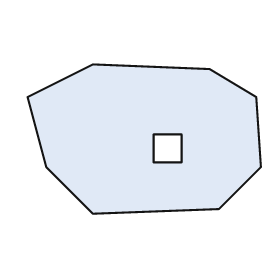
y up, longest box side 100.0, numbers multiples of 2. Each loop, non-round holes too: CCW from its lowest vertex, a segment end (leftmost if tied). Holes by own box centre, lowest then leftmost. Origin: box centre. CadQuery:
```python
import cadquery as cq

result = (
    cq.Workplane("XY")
    .moveTo(-22.0, -32.0)
    .lineTo(32.0, -30.0)
    .lineTo(50.0, -12.0)
    .lineTo(48.0, 18.0)
    .lineTo(28.0, 30.0)
    .lineTo(-22.0, 32.0)
    .lineTo(-50.0, 18.0)
    .lineTo(-42.0, -12.0)
    .close()
    .moveTo(4.0, -10.0)
    .lineTo(16.0, -10.0)
    .lineTo(16.0, 2.0)
    .lineTo(4.0, 2.0)
    .close()
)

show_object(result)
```